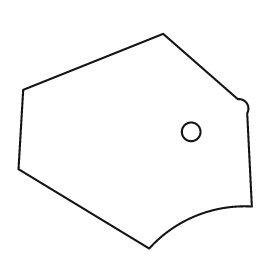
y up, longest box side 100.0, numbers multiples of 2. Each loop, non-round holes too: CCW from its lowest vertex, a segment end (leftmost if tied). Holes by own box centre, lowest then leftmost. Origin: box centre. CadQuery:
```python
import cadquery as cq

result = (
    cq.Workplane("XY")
    .moveTo(6.0, -46.0)
    .threePointArc((26.0, -32.0), (50.0, -28.0))
    .lineTo(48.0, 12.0)
    .threePointArc((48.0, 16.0), (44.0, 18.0))
    .lineTo(12.0, 46.0)
    .lineTo(-48.0, 22.0)
    .lineTo(-50.0, -12.0)
    .close()
    .moveTo(24.0, 4.0)
    .circle(4.0)
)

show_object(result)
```